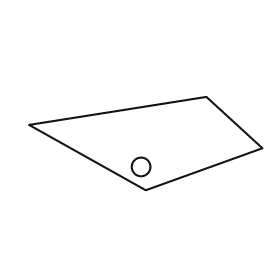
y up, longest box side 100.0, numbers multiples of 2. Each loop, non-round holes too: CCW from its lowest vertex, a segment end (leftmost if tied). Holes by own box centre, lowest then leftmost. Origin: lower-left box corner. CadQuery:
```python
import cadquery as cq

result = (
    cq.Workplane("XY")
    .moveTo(50.0, 0.0)
    .lineTo(100.0, 18.0)
    .lineTo(76.0, 40.0)
    .lineTo(0.0, 28.0)
    .close()
    .moveTo(48.0, 10.0)
    .circle(4.0)
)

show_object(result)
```